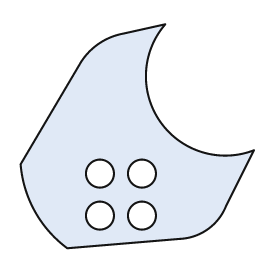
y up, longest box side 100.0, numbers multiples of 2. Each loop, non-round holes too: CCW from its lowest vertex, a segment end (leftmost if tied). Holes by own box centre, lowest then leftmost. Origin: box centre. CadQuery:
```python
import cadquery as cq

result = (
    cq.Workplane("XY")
    .moveTo(-30.0, -48.0)
    .lineTo(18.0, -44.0)
    .threePointArc((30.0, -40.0), (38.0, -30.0))
    .lineTo(50.0, -6.0)
    .threePointArc((10.0, 6.0), (12.0, 48.0))
    .lineTo(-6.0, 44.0)
    .threePointArc((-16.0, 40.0), (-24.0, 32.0))
    .lineTo(-50.0, -12.0)
    .threePointArc((-44.0, -32.0), (-30.0, -48.0))
    .close()
    .moveTo(-16.0, -34.0)
    .circle(6.0)
    .moveTo(2.0, -34.0)
    .circle(6.0)
    .moveTo(-16.0, -16.0)
    .circle(6.0)
    .moveTo(2.0, -16.0)
    .circle(6.0)
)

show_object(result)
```